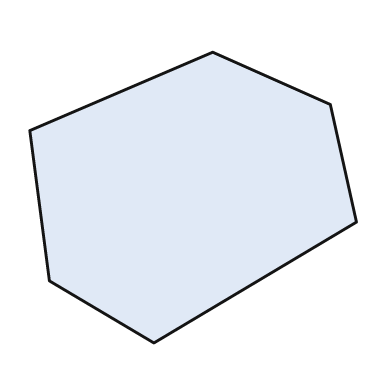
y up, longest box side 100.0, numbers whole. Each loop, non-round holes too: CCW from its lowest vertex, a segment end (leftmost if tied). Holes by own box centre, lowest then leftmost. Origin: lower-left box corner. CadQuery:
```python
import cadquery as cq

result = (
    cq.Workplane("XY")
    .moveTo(38.0, 0.0)
    .lineTo(100.0, 37.0)
    .lineTo(92.0, 73.0)
    .lineTo(56.0, 89.0)
    .lineTo(0.0, 65.0)
    .lineTo(6.0, 19.0)
    .close()
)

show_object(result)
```